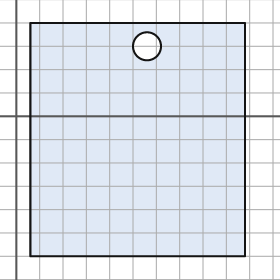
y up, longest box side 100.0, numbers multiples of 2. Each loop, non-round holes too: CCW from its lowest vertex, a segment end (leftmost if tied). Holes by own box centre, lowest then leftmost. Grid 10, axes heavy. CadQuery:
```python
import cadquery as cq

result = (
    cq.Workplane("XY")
    .moveTo(6.0, -60.0)
    .lineTo(98.0, -60.0)
    .lineTo(98.0, 40.0)
    .lineTo(6.0, 40.0)
    .close()
    .moveTo(56.0, 30.0)
    .circle(6.0)
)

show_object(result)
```